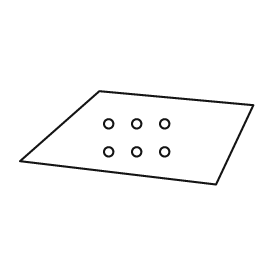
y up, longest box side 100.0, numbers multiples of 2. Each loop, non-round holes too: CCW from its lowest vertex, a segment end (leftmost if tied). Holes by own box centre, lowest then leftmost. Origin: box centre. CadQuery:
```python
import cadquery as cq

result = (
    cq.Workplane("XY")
    .moveTo(34.0, -20.0)
    .lineTo(50.0, 14.0)
    .lineTo(-16.0, 20.0)
    .lineTo(-50.0, -10.0)
    .close()
    .moveTo(-12.0, -6.0)
    .circle(2.0)
    .moveTo(0.0, -6.0)
    .circle(2.0)
    .moveTo(12.0, -6.0)
    .circle(2.0)
    .moveTo(-12.0, 6.0)
    .circle(2.0)
    .moveTo(0.0, 6.0)
    .circle(2.0)
    .moveTo(12.0, 6.0)
    .circle(2.0)
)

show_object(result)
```